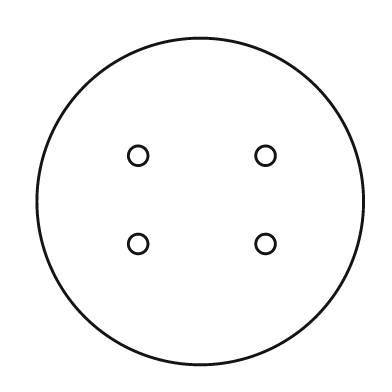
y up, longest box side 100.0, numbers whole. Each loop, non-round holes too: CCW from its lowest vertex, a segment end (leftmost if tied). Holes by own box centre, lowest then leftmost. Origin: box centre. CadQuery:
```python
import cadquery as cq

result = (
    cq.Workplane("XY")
    .moveTo(0.0, 0.0)
    .circle(50.0)
    .moveTo(-19.0, -13.0)
    .circle(3.0)
    .moveTo(20.0, -13.0)
    .circle(3.0)
    .moveTo(-19.0, 14.0)
    .circle(3.0)
    .moveTo(20.0, 14.0)
    .circle(3.0)
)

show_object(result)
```